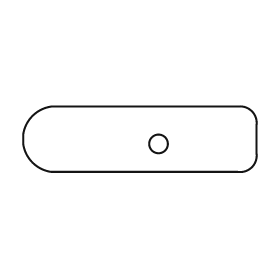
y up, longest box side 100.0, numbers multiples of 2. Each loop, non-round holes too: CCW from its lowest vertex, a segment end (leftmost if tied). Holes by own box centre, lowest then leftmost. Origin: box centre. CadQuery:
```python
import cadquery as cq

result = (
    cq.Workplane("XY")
    .moveTo(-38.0, -14.0)
    .lineTo(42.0, -14.0)
    .threePointArc((48.0, -12.0), (50.0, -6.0))
    .lineTo(50.0, 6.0)
    .threePointArc((48.0, 12.0), (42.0, 14.0))
    .lineTo(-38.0, 14.0)
    .threePointArc((-46.0, 10.0), (-50.0, 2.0))
    .lineTo(-50.0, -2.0)
    .threePointArc((-46.0, -10.0), (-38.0, -14.0))
    .close()
    .moveTo(8.0, -2.0)
    .circle(4.0)
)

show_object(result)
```